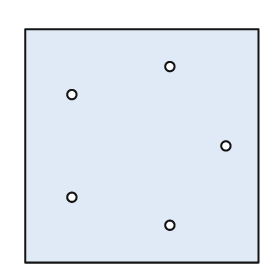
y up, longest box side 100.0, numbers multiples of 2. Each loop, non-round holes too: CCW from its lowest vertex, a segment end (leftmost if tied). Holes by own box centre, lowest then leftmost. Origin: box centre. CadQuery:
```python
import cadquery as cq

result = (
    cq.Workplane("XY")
    .moveTo(-50.0, -50.0)
    .lineTo(50.0, -50.0)
    .lineTo(50.0, 50.0)
    .lineTo(-50.0, 50.0)
    .close()
    .moveTo(12.0, -34.0)
    .circle(2.0)
    .moveTo(-30.0, -22.0)
    .circle(2.0)
    .moveTo(36.0, 0.0)
    .circle(2.0)
    .moveTo(-30.0, 22.0)
    .circle(2.0)
    .moveTo(12.0, 34.0)
    .circle(2.0)
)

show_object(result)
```